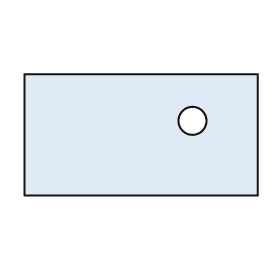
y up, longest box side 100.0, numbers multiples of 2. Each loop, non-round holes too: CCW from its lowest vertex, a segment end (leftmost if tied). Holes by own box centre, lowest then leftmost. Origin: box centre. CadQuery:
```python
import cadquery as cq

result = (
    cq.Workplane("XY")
    .moveTo(-50.0, -26.0)
    .lineTo(50.0, -26.0)
    .lineTo(50.0, 26.0)
    .lineTo(-50.0, 26.0)
    .close()
    .moveTo(22.0, 6.0)
    .circle(6.0)
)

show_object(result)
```